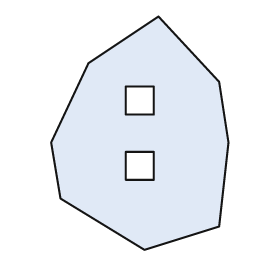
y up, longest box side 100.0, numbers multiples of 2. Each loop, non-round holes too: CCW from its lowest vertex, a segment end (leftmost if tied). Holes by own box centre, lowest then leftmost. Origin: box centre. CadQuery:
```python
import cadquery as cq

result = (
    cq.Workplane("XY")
    .moveTo(2.0, -50.0)
    .lineTo(34.0, -40.0)
    .lineTo(38.0, -4.0)
    .lineTo(34.0, 22.0)
    .lineTo(8.0, 50.0)
    .lineTo(-22.0, 30.0)
    .lineTo(-38.0, -4.0)
    .lineTo(-34.0, -28.0)
    .close()
    .moveTo(-6.0, -20.0)
    .lineTo(6.0, -20.0)
    .lineTo(6.0, -8.0)
    .lineTo(-6.0, -8.0)
    .close()
    .moveTo(-6.0, 8.0)
    .lineTo(6.0, 8.0)
    .lineTo(6.0, 20.0)
    .lineTo(-6.0, 20.0)
    .close()
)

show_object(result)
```